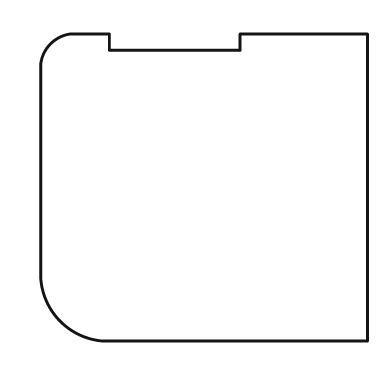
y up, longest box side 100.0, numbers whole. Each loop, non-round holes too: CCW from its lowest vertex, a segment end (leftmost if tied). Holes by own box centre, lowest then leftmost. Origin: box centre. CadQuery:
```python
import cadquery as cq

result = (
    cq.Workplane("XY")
    .moveTo(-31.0, -47.0)
    .lineTo(50.0, -47.0)
    .lineTo(50.0, 47.0)
    .lineTo(11.0, 47.0)
    .lineTo(11.0, 42.0)
    .lineTo(-29.0, 42.0)
    .lineTo(-29.0, 47.0)
    .lineTo(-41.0, 47.0)
    .threePointArc((-47.0, 44.0), (-50.0, 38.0))
    .lineTo(-50.0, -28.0)
    .threePointArc((-44.0, -41.0), (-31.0, -47.0))
    .close()
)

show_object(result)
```